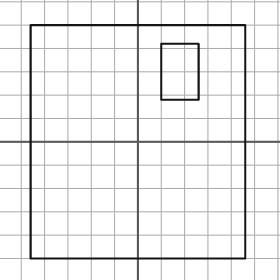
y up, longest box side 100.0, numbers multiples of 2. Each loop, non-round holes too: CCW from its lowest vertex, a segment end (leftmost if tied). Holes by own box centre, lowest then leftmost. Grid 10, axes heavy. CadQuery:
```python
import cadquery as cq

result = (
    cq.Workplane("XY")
    .moveTo(-46.0, -50.0)
    .lineTo(46.0, -50.0)
    .lineTo(46.0, 50.0)
    .lineTo(-46.0, 50.0)
    .close()
    .moveTo(10.0, 18.0)
    .lineTo(26.0, 18.0)
    .lineTo(26.0, 42.0)
    .lineTo(10.0, 42.0)
    .close()
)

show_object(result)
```